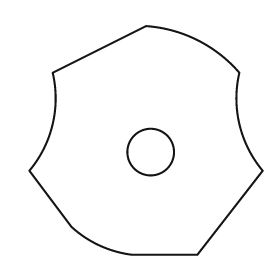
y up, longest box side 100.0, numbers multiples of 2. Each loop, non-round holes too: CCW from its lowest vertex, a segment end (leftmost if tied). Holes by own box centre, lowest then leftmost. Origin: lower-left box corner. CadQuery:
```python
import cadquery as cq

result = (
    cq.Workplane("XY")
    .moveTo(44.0, 0.0)
    .lineTo(72.0, 0.0)
    .lineTo(100.0, 36.0)
    .threePointArc((90.0, 56.0), (90.0, 78.0))
    .threePointArc((72.0, 92.0), (50.0, 98.0))
    .lineTo(10.0, 78.0)
    .threePointArc((10.0, 56.0), (0.0, 36.0))
    .lineTo(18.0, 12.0)
    .threePointArc((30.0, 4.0), (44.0, 0.0))
    .close()
    .moveTo(52.0, 44.0)
    .circle(10.0)
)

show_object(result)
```